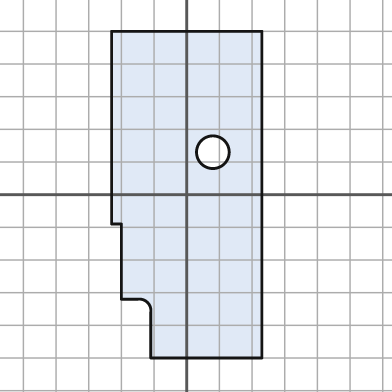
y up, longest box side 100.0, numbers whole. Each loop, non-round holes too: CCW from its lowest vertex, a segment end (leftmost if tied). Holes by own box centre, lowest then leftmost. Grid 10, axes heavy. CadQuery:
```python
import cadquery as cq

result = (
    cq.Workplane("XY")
    .moveTo(-11.0, -50.0)
    .lineTo(23.0, -50.0)
    .lineTo(23.0, 50.0)
    .lineTo(-23.0, 50.0)
    .lineTo(-23.0, -9.0)
    .lineTo(-20.0, -9.0)
    .lineTo(-20.0, -32.0)
    .lineTo(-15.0, -32.0)
    .threePointArc((-12.0, -33.0), (-11.0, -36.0))
    .close()
    .moveTo(8.0, 13.0)
    .circle(5.0)
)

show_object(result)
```